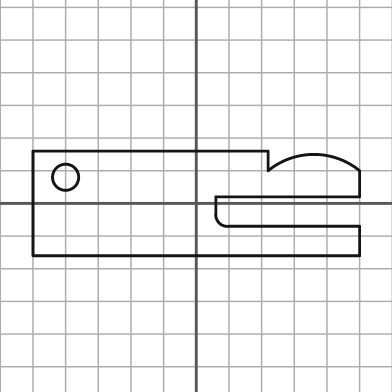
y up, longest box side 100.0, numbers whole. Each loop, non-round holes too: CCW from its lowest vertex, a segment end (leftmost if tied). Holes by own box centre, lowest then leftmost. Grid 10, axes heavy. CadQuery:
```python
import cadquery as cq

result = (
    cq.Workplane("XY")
    .moveTo(-50.0, -16.0)
    .lineTo(50.0, -16.0)
    .lineTo(50.0, -7.0)
    .lineTo(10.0, -7.0)
    .threePointArc((7.0, -6.0), (6.0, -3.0))
    .lineTo(6.0, 2.0)
    .lineTo(50.0, 2.0)
    .lineTo(50.0, 10.0)
    .threePointArc((36.0, 15.0), (22.0, 10.0))
    .lineTo(22.0, 16.0)
    .lineTo(-50.0, 16.0)
    .close()
    .moveTo(-40.0, 8.0)
    .circle(4.0)
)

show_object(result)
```